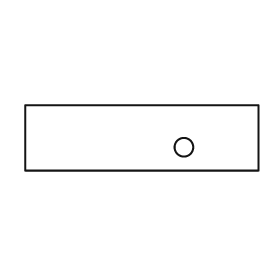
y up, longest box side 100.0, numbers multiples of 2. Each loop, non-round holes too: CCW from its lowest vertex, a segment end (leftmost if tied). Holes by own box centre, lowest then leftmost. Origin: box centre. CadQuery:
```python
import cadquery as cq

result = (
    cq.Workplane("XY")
    .moveTo(-50.0, -14.0)
    .lineTo(50.0, -14.0)
    .lineTo(50.0, 14.0)
    .lineTo(-50.0, 14.0)
    .close()
    .moveTo(18.0, -4.0)
    .circle(4.0)
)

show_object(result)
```